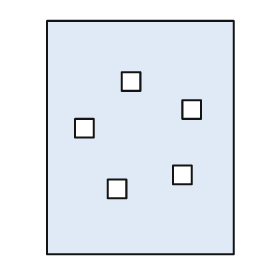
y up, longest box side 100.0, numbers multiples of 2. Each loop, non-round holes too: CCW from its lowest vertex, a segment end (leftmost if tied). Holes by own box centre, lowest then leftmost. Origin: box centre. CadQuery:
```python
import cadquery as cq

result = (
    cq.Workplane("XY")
    .moveTo(-40.0, -50.0)
    .lineTo(40.0, -50.0)
    .lineTo(40.0, 50.0)
    .lineTo(-40.0, 50.0)
    .close()
    .moveTo(-14.0, -26.0)
    .lineTo(-6.0, -26.0)
    .lineTo(-6.0, -18.0)
    .lineTo(-14.0, -18.0)
    .close()
    .moveTo(14.0, -20.0)
    .lineTo(22.0, -20.0)
    .lineTo(22.0, -12.0)
    .lineTo(14.0, -12.0)
    .close()
    .moveTo(-28.0, 0.0)
    .lineTo(-20.0, 0.0)
    .lineTo(-20.0, 8.0)
    .lineTo(-28.0, 8.0)
    .close()
    .moveTo(18.0, 8.0)
    .lineTo(26.0, 8.0)
    .lineTo(26.0, 16.0)
    .lineTo(18.0, 16.0)
    .close()
    .moveTo(-8.0, 20.0)
    .lineTo(0.0, 20.0)
    .lineTo(0.0, 28.0)
    .lineTo(-8.0, 28.0)
    .close()
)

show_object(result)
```